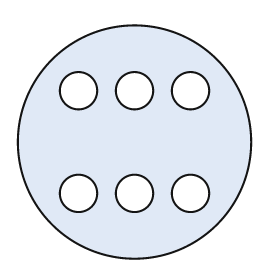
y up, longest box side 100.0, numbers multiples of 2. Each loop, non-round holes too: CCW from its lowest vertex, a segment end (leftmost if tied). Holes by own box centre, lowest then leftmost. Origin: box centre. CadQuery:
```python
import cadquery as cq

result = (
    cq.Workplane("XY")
    .moveTo(0.0, 0.0)
    .circle(50.0)
    .moveTo(-24.0, -22.0)
    .circle(8.0)
    .moveTo(0.0, -22.0)
    .circle(8.0)
    .moveTo(24.0, -22.0)
    .circle(8.0)
    .moveTo(-24.0, 22.0)
    .circle(8.0)
    .moveTo(0.0, 22.0)
    .circle(8.0)
    .moveTo(24.0, 22.0)
    .circle(8.0)
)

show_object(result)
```